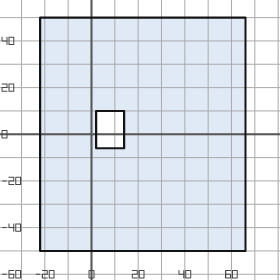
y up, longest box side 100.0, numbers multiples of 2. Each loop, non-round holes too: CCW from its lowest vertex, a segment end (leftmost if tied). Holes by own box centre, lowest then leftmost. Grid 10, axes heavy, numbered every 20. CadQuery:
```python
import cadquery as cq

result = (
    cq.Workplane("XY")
    .moveTo(-22.0, -50.0)
    .lineTo(66.0, -50.0)
    .lineTo(66.0, 50.0)
    .lineTo(-22.0, 50.0)
    .close()
    .moveTo(2.0, -6.0)
    .lineTo(14.0, -6.0)
    .lineTo(14.0, 10.0)
    .lineTo(2.0, 10.0)
    .close()
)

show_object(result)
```